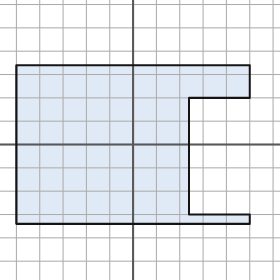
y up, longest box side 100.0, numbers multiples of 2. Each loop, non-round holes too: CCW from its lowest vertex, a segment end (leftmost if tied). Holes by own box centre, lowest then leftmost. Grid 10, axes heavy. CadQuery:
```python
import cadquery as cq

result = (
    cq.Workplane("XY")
    .moveTo(-50.0, -34.0)
    .lineTo(50.0, -34.0)
    .lineTo(50.0, -30.0)
    .lineTo(24.0, -30.0)
    .lineTo(24.0, 20.0)
    .lineTo(50.0, 20.0)
    .lineTo(50.0, 34.0)
    .lineTo(-50.0, 34.0)
    .close()
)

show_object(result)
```